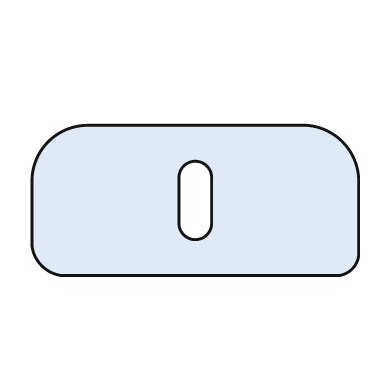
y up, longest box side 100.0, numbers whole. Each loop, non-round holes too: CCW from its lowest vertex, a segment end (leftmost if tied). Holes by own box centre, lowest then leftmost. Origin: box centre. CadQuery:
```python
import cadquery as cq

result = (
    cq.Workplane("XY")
    .moveTo(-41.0, -23.0)
    .lineTo(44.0, -23.0)
    .threePointArc((48.0, -21.0), (50.0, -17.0))
    .lineTo(50.0, 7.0)
    .threePointArc((45.0, 18.0), (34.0, 23.0))
    .lineTo(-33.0, 23.0)
    .threePointArc((-45.0, 18.0), (-50.0, 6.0))
    .lineTo(-50.0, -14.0)
    .threePointArc((-47.0, -20.0), (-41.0, -23.0))
    .close()
    .moveTo(-5.0, -7.0)
    .threePointArc((0.0, -12.0), (5.0, -7.0))
    .lineTo(5.0, 7.0)
    .threePointArc((0.0, 12.0), (-5.0, 7.0))
    .close()
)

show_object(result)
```